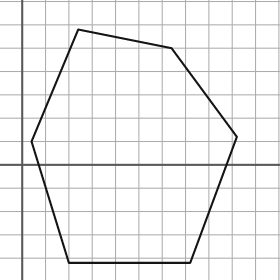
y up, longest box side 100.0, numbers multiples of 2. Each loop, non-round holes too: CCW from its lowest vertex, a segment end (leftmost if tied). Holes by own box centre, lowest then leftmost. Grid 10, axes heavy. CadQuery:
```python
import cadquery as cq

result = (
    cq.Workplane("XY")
    .moveTo(20.0, -42.0)
    .lineTo(72.0, -42.0)
    .lineTo(92.0, 12.0)
    .lineTo(64.0, 50.0)
    .lineTo(24.0, 58.0)
    .lineTo(4.0, 10.0)
    .close()
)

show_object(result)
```